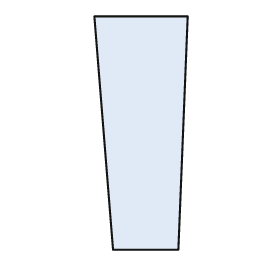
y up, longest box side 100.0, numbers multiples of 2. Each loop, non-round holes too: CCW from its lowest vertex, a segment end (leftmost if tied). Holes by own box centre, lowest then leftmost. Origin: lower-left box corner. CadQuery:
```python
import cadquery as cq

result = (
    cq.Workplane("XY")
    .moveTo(8.0, 0.0)
    .lineTo(36.0, 0.0)
    .lineTo(40.0, 100.0)
    .lineTo(0.0, 100.0)
    .close()
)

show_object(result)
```